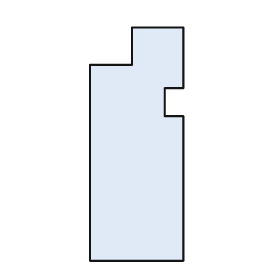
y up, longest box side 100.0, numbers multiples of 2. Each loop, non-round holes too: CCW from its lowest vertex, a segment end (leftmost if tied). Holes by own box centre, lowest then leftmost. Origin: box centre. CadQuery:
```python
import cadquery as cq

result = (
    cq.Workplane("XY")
    .moveTo(-20.0, -50.0)
    .lineTo(20.0, -50.0)
    .lineTo(20.0, 12.0)
    .lineTo(12.0, 12.0)
    .lineTo(12.0, 24.0)
    .lineTo(20.0, 24.0)
    .lineTo(20.0, 50.0)
    .lineTo(-2.0, 50.0)
    .lineTo(-2.0, 34.0)
    .lineTo(-20.0, 34.0)
    .close()
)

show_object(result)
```